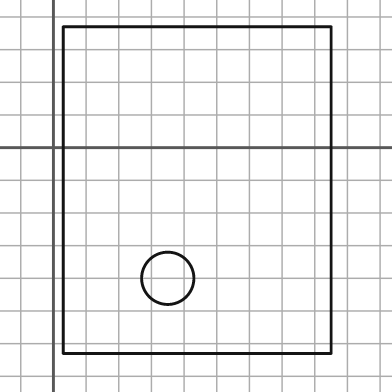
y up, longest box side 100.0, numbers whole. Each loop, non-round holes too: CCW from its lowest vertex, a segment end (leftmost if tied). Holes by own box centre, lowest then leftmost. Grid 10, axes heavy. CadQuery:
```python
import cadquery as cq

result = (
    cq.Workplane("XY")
    .moveTo(3.0, -63.0)
    .lineTo(85.0, -63.0)
    .lineTo(85.0, 37.0)
    .lineTo(3.0, 37.0)
    .close()
    .moveTo(35.0, -40.0)
    .circle(8.0)
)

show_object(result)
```